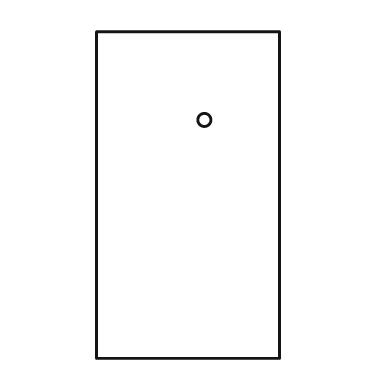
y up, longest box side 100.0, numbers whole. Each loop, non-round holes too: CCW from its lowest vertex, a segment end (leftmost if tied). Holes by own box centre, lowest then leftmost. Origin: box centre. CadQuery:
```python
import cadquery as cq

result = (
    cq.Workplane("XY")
    .moveTo(-28.0, -50.0)
    .lineTo(28.0, -50.0)
    .lineTo(28.0, 50.0)
    .lineTo(-28.0, 50.0)
    .close()
    .moveTo(5.0, 23.0)
    .circle(2.0)
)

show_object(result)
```